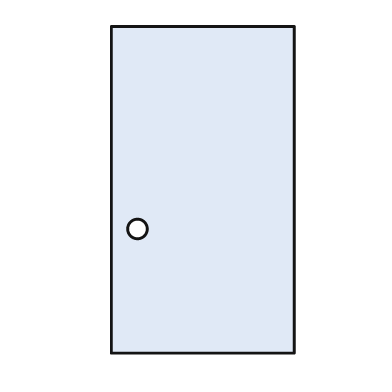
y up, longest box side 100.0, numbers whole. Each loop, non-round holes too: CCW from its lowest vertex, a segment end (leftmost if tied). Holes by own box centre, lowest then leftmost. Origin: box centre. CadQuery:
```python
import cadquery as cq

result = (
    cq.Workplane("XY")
    .moveTo(-28.0, -50.0)
    .lineTo(28.0, -50.0)
    .lineTo(28.0, 50.0)
    .lineTo(-28.0, 50.0)
    .close()
    .moveTo(-20.0, -12.0)
    .circle(3.0)
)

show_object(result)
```